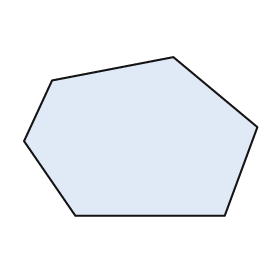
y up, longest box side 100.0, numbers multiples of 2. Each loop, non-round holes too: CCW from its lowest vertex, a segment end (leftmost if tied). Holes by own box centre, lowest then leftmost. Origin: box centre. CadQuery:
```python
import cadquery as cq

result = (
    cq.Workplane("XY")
    .moveTo(-28.0, -34.0)
    .lineTo(36.0, -34.0)
    .lineTo(50.0, 4.0)
    .lineTo(14.0, 34.0)
    .lineTo(-38.0, 24.0)
    .lineTo(-50.0, -2.0)
    .close()
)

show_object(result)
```